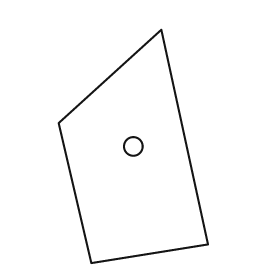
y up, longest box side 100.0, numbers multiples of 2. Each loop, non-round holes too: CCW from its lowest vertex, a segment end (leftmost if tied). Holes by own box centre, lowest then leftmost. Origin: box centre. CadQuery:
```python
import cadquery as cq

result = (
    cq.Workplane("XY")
    .moveTo(-18.0, -50.0)
    .lineTo(32.0, -42.0)
    .lineTo(12.0, 50.0)
    .lineTo(-32.0, 10.0)
    .close()
    .moveTo(0.0, 0.0)
    .circle(4.0)
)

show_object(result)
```